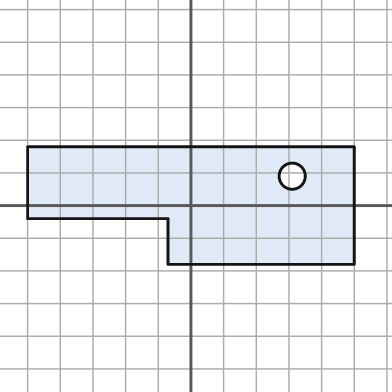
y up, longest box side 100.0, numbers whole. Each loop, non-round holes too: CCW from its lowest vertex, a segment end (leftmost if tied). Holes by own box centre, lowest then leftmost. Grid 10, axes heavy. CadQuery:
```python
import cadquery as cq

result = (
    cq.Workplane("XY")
    .moveTo(-7.0, -18.0)
    .lineTo(50.0, -18.0)
    .lineTo(50.0, 18.0)
    .lineTo(-50.0, 18.0)
    .lineTo(-50.0, -4.0)
    .lineTo(-7.0, -4.0)
    .close()
    .moveTo(31.0, 9.0)
    .circle(4.0)
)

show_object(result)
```